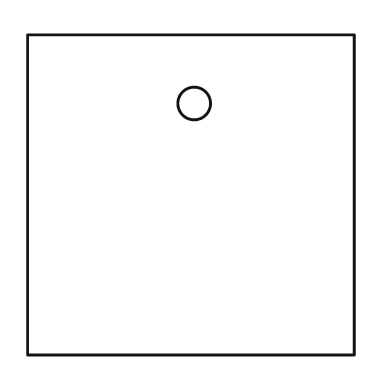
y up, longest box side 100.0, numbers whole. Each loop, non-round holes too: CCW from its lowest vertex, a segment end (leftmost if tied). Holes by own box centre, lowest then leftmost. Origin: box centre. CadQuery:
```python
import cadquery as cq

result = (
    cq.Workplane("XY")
    .moveTo(-50.0, -49.0)
    .lineTo(50.0, -49.0)
    .lineTo(50.0, 49.0)
    .lineTo(-50.0, 49.0)
    .close()
    .moveTo(1.0, 28.0)
    .circle(5.0)
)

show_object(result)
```